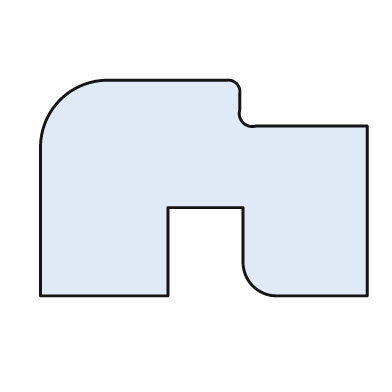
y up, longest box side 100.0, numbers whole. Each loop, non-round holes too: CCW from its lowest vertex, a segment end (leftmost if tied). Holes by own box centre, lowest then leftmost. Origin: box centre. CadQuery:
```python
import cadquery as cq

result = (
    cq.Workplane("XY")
    .moveTo(-50.0, -33.0)
    .lineTo(-11.0, -33.0)
    .lineTo(-11.0, -6.0)
    .lineTo(12.0, -6.0)
    .lineTo(12.0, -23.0)
    .threePointArc((15.0, -30.0), (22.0, -33.0))
    .lineTo(50.0, -33.0)
    .lineTo(50.0, 19.0)
    .lineTo(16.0, 19.0)
    .threePointArc((12.0, 20.0), (11.0, 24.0))
    .lineTo(11.0, 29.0)
    .threePointArc((10.0, 32.0), (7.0, 33.0))
    .lineTo(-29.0, 33.0)
    .threePointArc((-44.0, 27.0), (-50.0, 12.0))
    .close()
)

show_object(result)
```